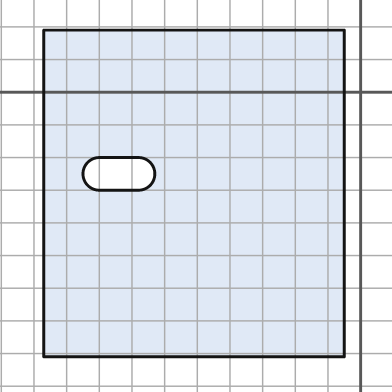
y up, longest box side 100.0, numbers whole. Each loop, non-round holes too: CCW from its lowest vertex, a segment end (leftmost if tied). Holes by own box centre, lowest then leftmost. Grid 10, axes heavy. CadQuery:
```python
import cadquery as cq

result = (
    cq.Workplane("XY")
    .moveTo(-97.0, -81.0)
    .lineTo(-5.0, -81.0)
    .lineTo(-5.0, 19.0)
    .lineTo(-97.0, 19.0)
    .close()
    .moveTo(-80.0, -30.0)
    .lineTo(-68.0, -30.0)
    .threePointArc((-63.0, -25.0), (-68.0, -20.0))
    .lineTo(-80.0, -20.0)
    .threePointArc((-85.0, -25.0), (-80.0, -30.0))
    .close()
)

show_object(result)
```